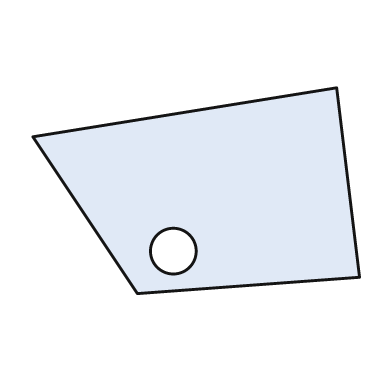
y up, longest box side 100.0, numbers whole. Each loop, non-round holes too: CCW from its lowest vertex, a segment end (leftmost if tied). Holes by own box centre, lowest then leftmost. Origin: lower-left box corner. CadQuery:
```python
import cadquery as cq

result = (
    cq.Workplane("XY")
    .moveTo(32.0, 0.0)
    .lineTo(100.0, 5.0)
    .lineTo(93.0, 63.0)
    .lineTo(0.0, 48.0)
    .close()
    .moveTo(43.0, 13.0)
    .circle(7.0)
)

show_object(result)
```